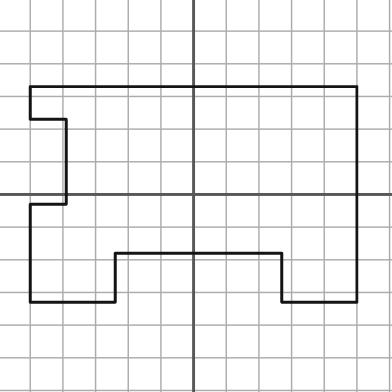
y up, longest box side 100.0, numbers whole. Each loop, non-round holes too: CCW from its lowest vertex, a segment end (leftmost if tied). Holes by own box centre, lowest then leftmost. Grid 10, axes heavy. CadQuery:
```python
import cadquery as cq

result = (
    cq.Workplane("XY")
    .moveTo(-50.0, -33.0)
    .lineTo(-24.0, -33.0)
    .lineTo(-24.0, -18.0)
    .lineTo(27.0, -18.0)
    .lineTo(27.0, -33.0)
    .lineTo(50.0, -33.0)
    .lineTo(50.0, 33.0)
    .lineTo(-50.0, 33.0)
    .lineTo(-50.0, 23.0)
    .lineTo(-39.0, 23.0)
    .lineTo(-39.0, -3.0)
    .lineTo(-50.0, -3.0)
    .close()
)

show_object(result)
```